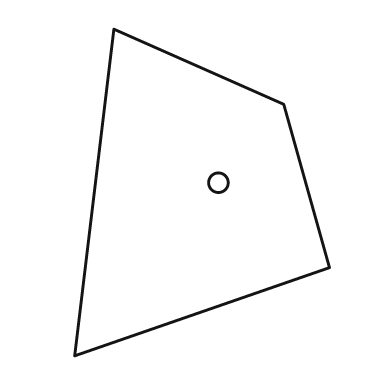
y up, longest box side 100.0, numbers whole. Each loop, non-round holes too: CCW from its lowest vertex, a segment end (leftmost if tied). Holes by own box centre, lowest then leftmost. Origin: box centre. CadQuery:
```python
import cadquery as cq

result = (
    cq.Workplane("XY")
    .moveTo(-39.0, -50.0)
    .lineTo(39.0, -23.0)
    .lineTo(25.0, 27.0)
    .lineTo(-27.0, 50.0)
    .close()
    .moveTo(5.0, 3.0)
    .circle(3.0)
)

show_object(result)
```